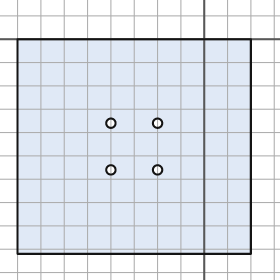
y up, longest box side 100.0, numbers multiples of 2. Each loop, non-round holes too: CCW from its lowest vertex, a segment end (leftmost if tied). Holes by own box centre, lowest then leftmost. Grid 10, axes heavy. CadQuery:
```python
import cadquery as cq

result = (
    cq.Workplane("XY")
    .moveTo(-80.0, -92.0)
    .lineTo(20.0, -92.0)
    .lineTo(20.0, 0.0)
    .lineTo(-80.0, 0.0)
    .close()
    .moveTo(-40.0, -56.0)
    .circle(2.0)
    .moveTo(-20.0, -56.0)
    .circle(2.0)
    .moveTo(-40.0, -36.0)
    .circle(2.0)
    .moveTo(-20.0, -36.0)
    .circle(2.0)
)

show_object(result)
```